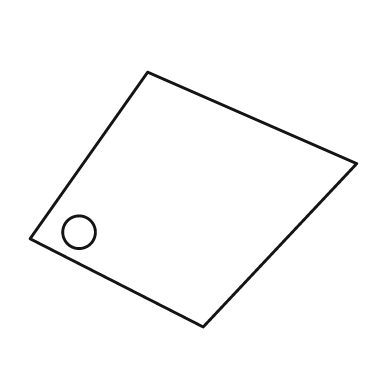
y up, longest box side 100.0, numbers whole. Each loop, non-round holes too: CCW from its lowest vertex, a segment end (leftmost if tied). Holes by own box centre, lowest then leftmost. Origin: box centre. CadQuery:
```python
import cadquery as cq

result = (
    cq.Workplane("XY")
    .moveTo(3.0, -39.0)
    .lineTo(50.0, 11.0)
    .lineTo(-14.0, 39.0)
    .lineTo(-50.0, -12.0)
    .close()
    .moveTo(-35.0, -10.0)
    .circle(5.0)
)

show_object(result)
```